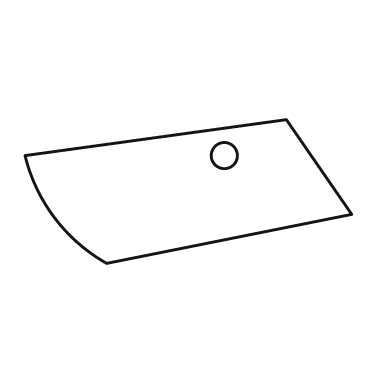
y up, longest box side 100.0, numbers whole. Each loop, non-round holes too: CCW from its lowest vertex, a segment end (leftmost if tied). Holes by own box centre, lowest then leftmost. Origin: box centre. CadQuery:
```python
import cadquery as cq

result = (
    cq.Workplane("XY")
    .moveTo(-25.0, -22.0)
    .lineTo(50.0, -7.0)
    .lineTo(30.0, 22.0)
    .lineTo(-50.0, 11.0)
    .threePointArc((-41.0, -8.0), (-25.0, -22.0))
    .close()
    .moveTo(11.0, 11.0)
    .circle(4.0)
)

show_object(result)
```